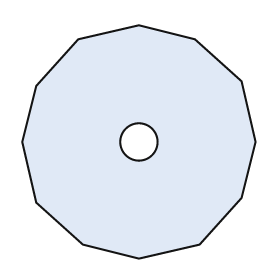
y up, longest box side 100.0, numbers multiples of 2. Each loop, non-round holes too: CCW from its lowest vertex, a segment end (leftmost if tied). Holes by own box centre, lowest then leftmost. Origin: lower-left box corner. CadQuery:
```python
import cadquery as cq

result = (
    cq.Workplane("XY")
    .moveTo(50.0, 0.0)
    .lineTo(76.0, 6.0)
    .lineTo(94.0, 26.0)
    .lineTo(100.0, 50.0)
    .lineTo(94.0, 76.0)
    .lineTo(74.0, 94.0)
    .lineTo(50.0, 100.0)
    .lineTo(24.0, 94.0)
    .lineTo(6.0, 74.0)
    .lineTo(0.0, 50.0)
    .lineTo(6.0, 24.0)
    .lineTo(26.0, 6.0)
    .close()
    .moveTo(50.0, 50.0)
    .circle(8.0)
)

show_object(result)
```